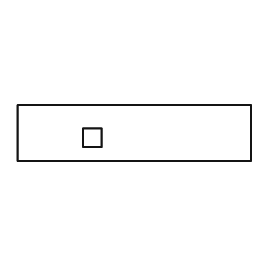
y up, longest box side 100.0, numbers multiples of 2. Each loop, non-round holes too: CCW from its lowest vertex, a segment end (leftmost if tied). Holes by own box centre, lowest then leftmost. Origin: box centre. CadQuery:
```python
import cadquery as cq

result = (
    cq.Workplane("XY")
    .moveTo(-50.0, -12.0)
    .lineTo(50.0, -12.0)
    .lineTo(50.0, 12.0)
    .lineTo(-50.0, 12.0)
    .close()
    .moveTo(-22.0, -6.0)
    .lineTo(-14.0, -6.0)
    .lineTo(-14.0, 2.0)
    .lineTo(-22.0, 2.0)
    .close()
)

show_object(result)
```